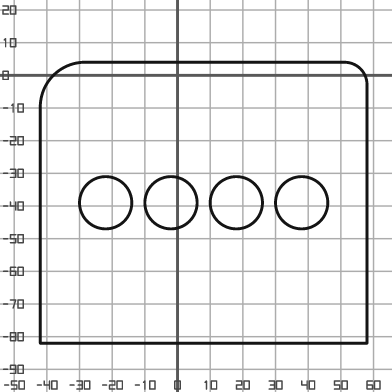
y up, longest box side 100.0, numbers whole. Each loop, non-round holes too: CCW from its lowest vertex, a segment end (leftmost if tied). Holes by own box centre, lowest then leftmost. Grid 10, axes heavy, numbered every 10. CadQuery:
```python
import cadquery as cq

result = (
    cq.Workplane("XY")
    .moveTo(-42.0, -82.0)
    .lineTo(58.0, -82.0)
    .lineTo(58.0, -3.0)
    .threePointArc((56.0, 2.0), (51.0, 4.0))
    .lineTo(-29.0, 4.0)
    .threePointArc((-38.0, 0.0), (-42.0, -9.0))
    .close()
    .moveTo(-22.0, -39.0)
    .circle(8.0)
    .moveTo(-2.0, -39.0)
    .circle(8.0)
    .moveTo(18.0, -39.0)
    .circle(8.0)
    .moveTo(38.0, -39.0)
    .circle(8.0)
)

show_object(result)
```